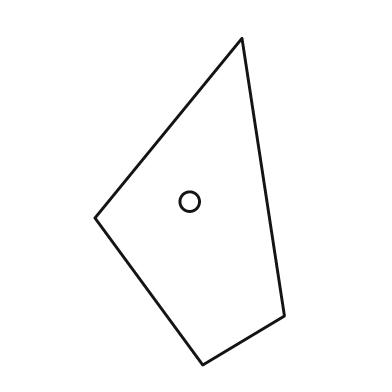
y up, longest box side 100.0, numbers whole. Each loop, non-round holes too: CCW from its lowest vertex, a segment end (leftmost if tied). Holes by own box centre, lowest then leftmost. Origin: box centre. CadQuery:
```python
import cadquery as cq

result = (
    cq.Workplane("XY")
    .moveTo(4.0, -50.0)
    .lineTo(29.0, -35.0)
    .lineTo(16.0, 50.0)
    .lineTo(-29.0, -5.0)
    .close()
    .moveTo(0.0, 0.0)
    .circle(3.0)
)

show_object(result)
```